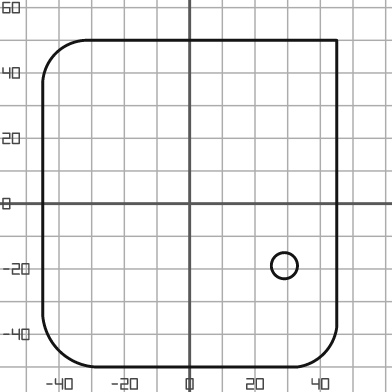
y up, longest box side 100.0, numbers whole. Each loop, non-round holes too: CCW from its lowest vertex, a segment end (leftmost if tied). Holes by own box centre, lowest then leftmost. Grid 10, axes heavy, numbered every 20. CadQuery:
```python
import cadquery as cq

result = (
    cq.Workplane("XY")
    .moveTo(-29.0, -50.0)
    .lineTo(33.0, -50.0)
    .threePointArc((41.0, -46.0), (45.0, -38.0))
    .lineTo(45.0, 50.0)
    .lineTo(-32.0, 50.0)
    .threePointArc((-41.0, 46.0), (-45.0, 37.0))
    .lineTo(-45.0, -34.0)
    .threePointArc((-40.0, -45.0), (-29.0, -50.0))
    .close()
    .moveTo(29.0, -19.0)
    .circle(4.0)
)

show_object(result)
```